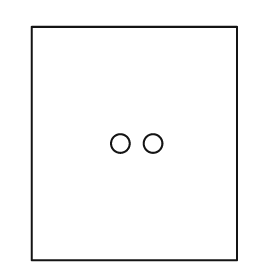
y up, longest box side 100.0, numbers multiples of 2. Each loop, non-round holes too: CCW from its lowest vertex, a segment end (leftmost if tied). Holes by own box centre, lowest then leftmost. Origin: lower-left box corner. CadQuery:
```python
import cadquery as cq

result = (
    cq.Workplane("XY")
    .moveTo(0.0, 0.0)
    .lineTo(88.0, 0.0)
    .lineTo(88.0, 100.0)
    .lineTo(0.0, 100.0)
    .close()
    .moveTo(38.0, 50.0)
    .circle(4.0)
    .moveTo(52.0, 50.0)
    .circle(4.0)
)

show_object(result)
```